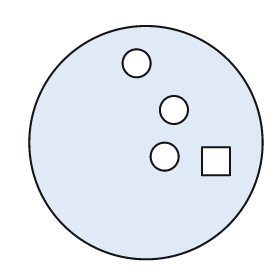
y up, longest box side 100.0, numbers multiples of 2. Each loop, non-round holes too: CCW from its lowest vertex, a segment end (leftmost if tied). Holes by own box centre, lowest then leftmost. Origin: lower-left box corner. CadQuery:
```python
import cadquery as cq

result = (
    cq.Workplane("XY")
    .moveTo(50.0, 50.0)
    .circle(50.0)
    .moveTo(74.0, 36.0)
    .lineTo(86.0, 36.0)
    .lineTo(86.0, 48.0)
    .lineTo(74.0, 48.0)
    .close()
    .moveTo(58.0, 44.0)
    .circle(6.0)
    .moveTo(62.0, 64.0)
    .circle(6.0)
    .moveTo(46.0, 84.0)
    .circle(6.0)
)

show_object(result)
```